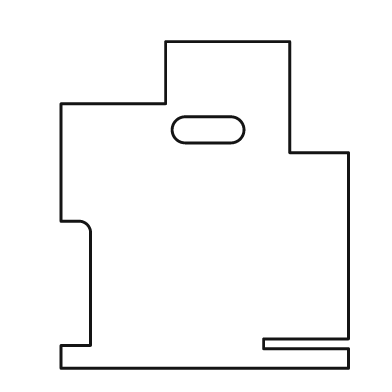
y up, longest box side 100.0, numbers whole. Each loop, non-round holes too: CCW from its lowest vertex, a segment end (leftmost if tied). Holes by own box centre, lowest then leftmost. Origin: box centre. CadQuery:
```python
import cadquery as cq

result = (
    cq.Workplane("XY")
    .moveTo(-44.0, -50.0)
    .lineTo(44.0, -50.0)
    .lineTo(44.0, -44.0)
    .lineTo(18.0, -44.0)
    .lineTo(18.0, -41.0)
    .lineTo(44.0, -41.0)
    .lineTo(44.0, 16.0)
    .lineTo(26.0, 16.0)
    .lineTo(26.0, 50.0)
    .lineTo(-12.0, 50.0)
    .lineTo(-12.0, 31.0)
    .lineTo(-44.0, 31.0)
    .lineTo(-44.0, -5.0)
    .lineTo(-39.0, -5.0)
    .threePointArc((-36.0, -6.0), (-35.0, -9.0))
    .lineTo(-35.0, -43.0)
    .lineTo(-44.0, -43.0)
    .close()
    .moveTo(-6.0, 19.0)
    .lineTo(8.0, 19.0)
    .threePointArc((12.0, 23.0), (8.0, 27.0))
    .lineTo(-6.0, 27.0)
    .threePointArc((-10.0, 23.0), (-6.0, 19.0))
    .close()
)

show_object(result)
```